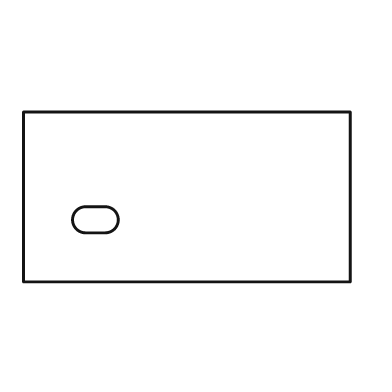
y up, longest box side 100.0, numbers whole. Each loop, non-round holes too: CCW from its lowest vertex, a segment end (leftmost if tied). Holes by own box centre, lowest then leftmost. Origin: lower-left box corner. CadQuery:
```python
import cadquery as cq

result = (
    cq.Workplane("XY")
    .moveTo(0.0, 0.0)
    .lineTo(100.0, 0.0)
    .lineTo(100.0, 52.0)
    .lineTo(0.0, 52.0)
    .close()
    .moveTo(19.0, 15.0)
    .lineTo(25.0, 15.0)
    .threePointArc((29.0, 19.0), (25.0, 23.0))
    .lineTo(19.0, 23.0)
    .threePointArc((15.0, 19.0), (19.0, 15.0))
    .close()
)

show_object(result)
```